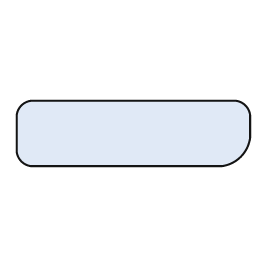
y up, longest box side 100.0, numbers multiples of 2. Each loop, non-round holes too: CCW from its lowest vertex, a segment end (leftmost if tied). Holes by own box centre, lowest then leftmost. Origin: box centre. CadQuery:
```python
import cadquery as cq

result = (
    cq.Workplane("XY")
    .moveTo(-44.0, -14.0)
    .lineTo(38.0, -14.0)
    .threePointArc((46.0, -10.0), (50.0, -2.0))
    .lineTo(50.0, 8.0)
    .threePointArc((48.0, 12.0), (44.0, 14.0))
    .lineTo(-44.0, 14.0)
    .threePointArc((-48.0, 12.0), (-50.0, 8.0))
    .lineTo(-50.0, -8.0)
    .threePointArc((-48.0, -12.0), (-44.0, -14.0))
    .close()
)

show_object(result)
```